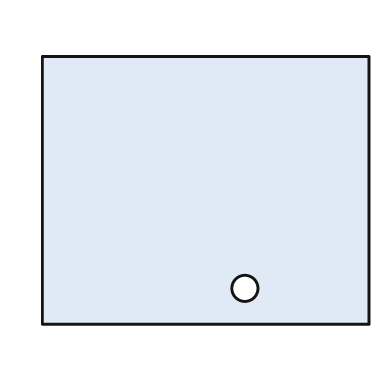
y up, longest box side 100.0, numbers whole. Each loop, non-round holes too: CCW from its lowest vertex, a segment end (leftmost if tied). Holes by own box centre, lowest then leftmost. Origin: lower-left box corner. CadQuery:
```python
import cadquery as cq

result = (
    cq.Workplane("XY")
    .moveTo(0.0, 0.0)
    .lineTo(100.0, 0.0)
    .lineTo(100.0, 82.0)
    .lineTo(0.0, 82.0)
    .close()
    .moveTo(62.0, 11.0)
    .circle(4.0)
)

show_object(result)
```